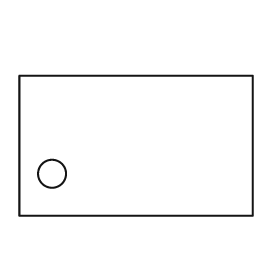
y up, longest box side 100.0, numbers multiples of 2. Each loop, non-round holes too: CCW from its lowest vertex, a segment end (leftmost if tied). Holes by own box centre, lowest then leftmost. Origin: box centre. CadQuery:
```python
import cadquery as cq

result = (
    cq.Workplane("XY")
    .moveTo(-50.0, -30.0)
    .lineTo(50.0, -30.0)
    .lineTo(50.0, 30.0)
    .lineTo(-50.0, 30.0)
    .close()
    .moveTo(-36.0, -12.0)
    .circle(6.0)
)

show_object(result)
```